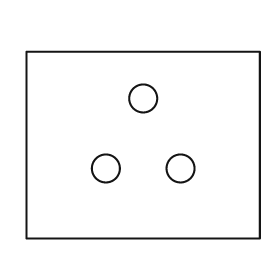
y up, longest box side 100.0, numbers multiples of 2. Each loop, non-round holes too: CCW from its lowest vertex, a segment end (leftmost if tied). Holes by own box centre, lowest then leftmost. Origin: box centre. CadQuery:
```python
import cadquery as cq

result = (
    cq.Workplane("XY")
    .moveTo(-50.0, -40.0)
    .lineTo(50.0, -40.0)
    .lineTo(50.0, 40.0)
    .lineTo(-50.0, 40.0)
    .close()
    .moveTo(-16.0, -10.0)
    .circle(6.0)
    .moveTo(16.0, -10.0)
    .circle(6.0)
    .moveTo(0.0, 20.0)
    .circle(6.0)
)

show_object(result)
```